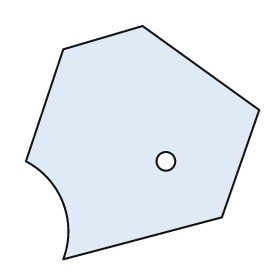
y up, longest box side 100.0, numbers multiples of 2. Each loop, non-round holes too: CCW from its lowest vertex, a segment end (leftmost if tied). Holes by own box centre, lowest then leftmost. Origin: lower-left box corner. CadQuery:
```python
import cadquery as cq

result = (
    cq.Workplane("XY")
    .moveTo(16.0, 0.0)
    .lineTo(84.0, 18.0)
    .lineTo(100.0, 64.0)
    .lineTo(50.0, 100.0)
    .lineTo(16.0, 90.0)
    .lineTo(0.0, 42.0)
    .threePointArc((16.0, 24.0), (16.0, 0.0))
    .close()
    .moveTo(60.0, 42.0)
    .circle(4.0)
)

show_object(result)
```